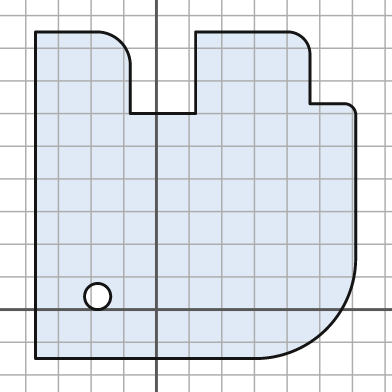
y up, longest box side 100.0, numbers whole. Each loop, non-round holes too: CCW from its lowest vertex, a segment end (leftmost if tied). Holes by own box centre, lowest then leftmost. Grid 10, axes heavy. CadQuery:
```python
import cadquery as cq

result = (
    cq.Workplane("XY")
    .moveTo(-37.0, -15.0)
    .lineTo(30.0, -15.0)
    .threePointArc((52.0, -6.0), (61.0, 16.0))
    .lineTo(61.0, 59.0)
    .threePointArc((60.0, 62.0), (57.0, 63.0))
    .lineTo(47.0, 63.0)
    .lineTo(47.0, 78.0)
    .threePointArc((45.0, 83.0), (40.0, 85.0))
    .lineTo(12.0, 85.0)
    .lineTo(12.0, 60.0)
    .lineTo(-8.0, 60.0)
    .lineTo(-8.0, 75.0)
    .threePointArc((-11.0, 82.0), (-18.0, 85.0))
    .lineTo(-37.0, 85.0)
    .close()
    .moveTo(-18.0, 4.0)
    .circle(4.0)
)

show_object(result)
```